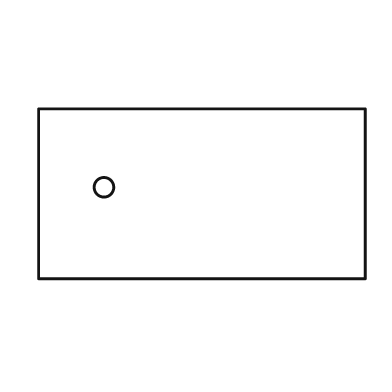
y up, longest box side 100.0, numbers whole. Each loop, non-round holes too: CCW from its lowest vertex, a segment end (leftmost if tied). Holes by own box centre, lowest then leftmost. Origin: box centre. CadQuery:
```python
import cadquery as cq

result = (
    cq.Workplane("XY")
    .moveTo(-50.0, -26.0)
    .lineTo(50.0, -26.0)
    .lineTo(50.0, 26.0)
    .lineTo(-50.0, 26.0)
    .close()
    .moveTo(-30.0, 2.0)
    .circle(3.0)
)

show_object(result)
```